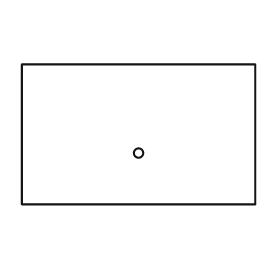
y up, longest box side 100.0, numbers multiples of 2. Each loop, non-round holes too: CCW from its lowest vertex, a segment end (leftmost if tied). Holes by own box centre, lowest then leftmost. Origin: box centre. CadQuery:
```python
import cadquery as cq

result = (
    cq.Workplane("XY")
    .moveTo(-50.0, -30.0)
    .lineTo(50.0, -30.0)
    .lineTo(50.0, 30.0)
    .lineTo(-50.0, 30.0)
    .close()
    .moveTo(0.0, -8.0)
    .circle(2.0)
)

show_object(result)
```